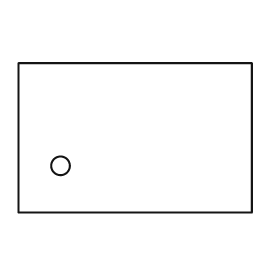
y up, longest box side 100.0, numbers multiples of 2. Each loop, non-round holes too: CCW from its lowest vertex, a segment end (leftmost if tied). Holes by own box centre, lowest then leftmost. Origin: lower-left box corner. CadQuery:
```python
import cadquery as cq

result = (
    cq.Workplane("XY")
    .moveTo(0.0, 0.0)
    .lineTo(100.0, 0.0)
    .lineTo(100.0, 64.0)
    .lineTo(0.0, 64.0)
    .close()
    .moveTo(18.0, 20.0)
    .circle(4.0)
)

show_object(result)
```